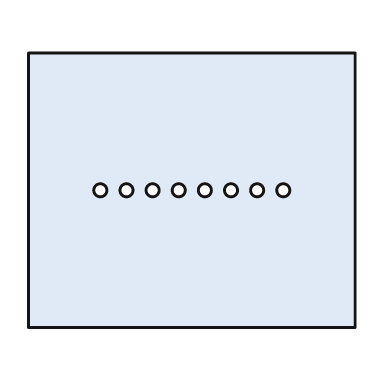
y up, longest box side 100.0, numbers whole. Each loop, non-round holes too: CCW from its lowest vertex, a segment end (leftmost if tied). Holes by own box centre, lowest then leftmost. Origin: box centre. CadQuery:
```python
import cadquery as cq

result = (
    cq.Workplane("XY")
    .moveTo(-50.0, -42.0)
    .lineTo(50.0, -42.0)
    .lineTo(50.0, 42.0)
    .lineTo(-50.0, 42.0)
    .close()
    .moveTo(-28.0, 0.0)
    .circle(2.0)
    .moveTo(-20.0, 0.0)
    .circle(2.0)
    .moveTo(-12.0, 0.0)
    .circle(2.0)
    .moveTo(-4.0, 0.0)
    .circle(2.0)
    .moveTo(4.0, 0.0)
    .circle(2.0)
    .moveTo(12.0, 0.0)
    .circle(2.0)
    .moveTo(20.0, 0.0)
    .circle(2.0)
    .moveTo(28.0, 0.0)
    .circle(2.0)
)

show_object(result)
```